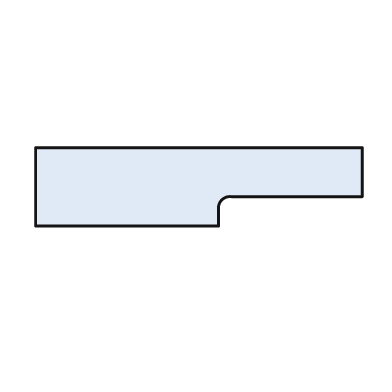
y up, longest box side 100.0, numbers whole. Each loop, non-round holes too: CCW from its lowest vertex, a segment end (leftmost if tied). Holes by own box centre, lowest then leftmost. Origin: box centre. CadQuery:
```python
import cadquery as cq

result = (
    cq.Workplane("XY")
    .moveTo(-50.0, -12.0)
    .lineTo(6.0, -12.0)
    .lineTo(6.0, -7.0)
    .threePointArc((7.0, -4.0), (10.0, -3.0))
    .lineTo(50.0, -3.0)
    .lineTo(50.0, 12.0)
    .lineTo(-50.0, 12.0)
    .close()
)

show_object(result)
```